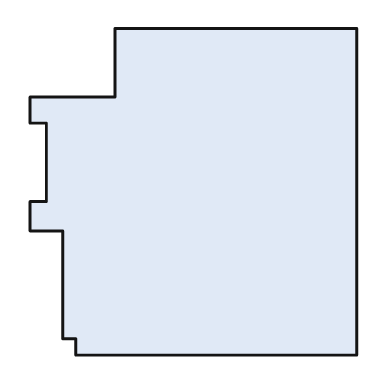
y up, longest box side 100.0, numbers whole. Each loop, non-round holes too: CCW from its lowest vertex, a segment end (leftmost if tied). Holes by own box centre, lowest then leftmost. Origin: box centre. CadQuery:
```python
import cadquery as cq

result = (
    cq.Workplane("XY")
    .moveTo(-36.0, -50.0)
    .lineTo(50.0, -50.0)
    .lineTo(50.0, 50.0)
    .lineTo(-24.0, 50.0)
    .lineTo(-24.0, 29.0)
    .lineTo(-50.0, 29.0)
    .lineTo(-50.0, 21.0)
    .lineTo(-45.0, 21.0)
    .lineTo(-45.0, -3.0)
    .lineTo(-50.0, -3.0)
    .lineTo(-50.0, -12.0)
    .lineTo(-40.0, -12.0)
    .lineTo(-40.0, -45.0)
    .lineTo(-36.0, -45.0)
    .close()
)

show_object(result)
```